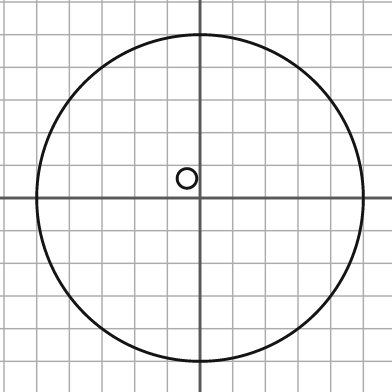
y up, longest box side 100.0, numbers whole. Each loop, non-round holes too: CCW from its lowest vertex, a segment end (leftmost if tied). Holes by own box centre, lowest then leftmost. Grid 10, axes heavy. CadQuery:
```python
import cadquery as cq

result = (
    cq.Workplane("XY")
    .moveTo(0.0, 0.0)
    .circle(50.0)
    .moveTo(-4.0, 6.0)
    .circle(3.0)
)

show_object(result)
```